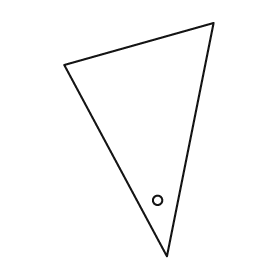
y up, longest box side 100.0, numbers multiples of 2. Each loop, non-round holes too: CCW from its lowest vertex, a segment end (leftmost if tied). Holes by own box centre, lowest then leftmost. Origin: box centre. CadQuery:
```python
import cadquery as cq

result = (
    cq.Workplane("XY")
    .moveTo(12.0, -50.0)
    .lineTo(32.0, 50.0)
    .lineTo(-32.0, 32.0)
    .close()
    .moveTo(8.0, -26.0)
    .circle(2.0)
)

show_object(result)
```